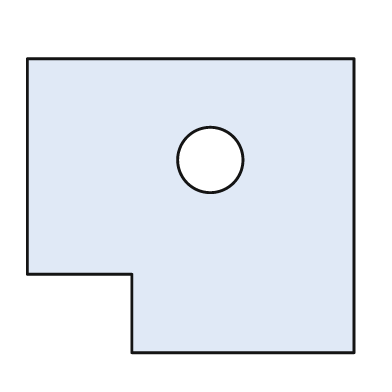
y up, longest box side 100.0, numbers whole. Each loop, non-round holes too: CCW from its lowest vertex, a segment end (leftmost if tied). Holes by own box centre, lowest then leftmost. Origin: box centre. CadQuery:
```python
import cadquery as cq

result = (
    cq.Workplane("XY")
    .moveTo(-18.0, -45.0)
    .lineTo(50.0, -45.0)
    .lineTo(50.0, 45.0)
    .lineTo(-50.0, 45.0)
    .lineTo(-50.0, -21.0)
    .lineTo(-18.0, -21.0)
    .close()
    .moveTo(6.0, 14.0)
    .circle(10.0)
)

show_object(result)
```